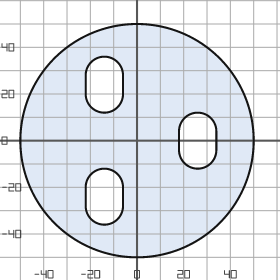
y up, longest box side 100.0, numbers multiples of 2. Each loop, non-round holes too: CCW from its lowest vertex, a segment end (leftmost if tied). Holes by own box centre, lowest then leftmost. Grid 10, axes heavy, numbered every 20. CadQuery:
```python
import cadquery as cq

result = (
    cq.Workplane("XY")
    .moveTo(0.0, 0.0)
    .circle(50.0)
    .moveTo(-22.0, -28.0)
    .threePointArc((-14.0, -36.0), (-6.0, -28.0))
    .lineTo(-6.0, -20.0)
    .threePointArc((-14.0, -12.0), (-22.0, -20.0))
    .close()
    .moveTo(18.0, -4.0)
    .threePointArc((26.0, -12.0), (34.0, -4.0))
    .lineTo(34.0, 4.0)
    .threePointArc((26.0, 12.0), (18.0, 4.0))
    .close()
    .moveTo(-22.0, 20.0)
    .threePointArc((-14.0, 12.0), (-6.0, 20.0))
    .lineTo(-6.0, 28.0)
    .threePointArc((-14.0, 36.0), (-22.0, 28.0))
    .close()
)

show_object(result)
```